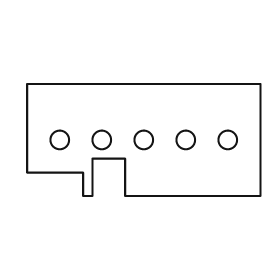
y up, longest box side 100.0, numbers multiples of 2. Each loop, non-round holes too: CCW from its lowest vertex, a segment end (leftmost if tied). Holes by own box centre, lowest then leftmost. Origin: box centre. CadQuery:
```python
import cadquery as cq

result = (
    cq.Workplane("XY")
    .moveTo(-26.0, -24.0)
    .lineTo(-22.0, -24.0)
    .lineTo(-22.0, -8.0)
    .lineTo(-8.0, -8.0)
    .lineTo(-8.0, -24.0)
    .lineTo(50.0, -24.0)
    .lineTo(50.0, 24.0)
    .lineTo(-50.0, 24.0)
    .lineTo(-50.0, -14.0)
    .lineTo(-26.0, -14.0)
    .close()
    .moveTo(-36.0, 0.0)
    .circle(4.0)
    .moveTo(-18.0, 0.0)
    .circle(4.0)
    .moveTo(0.0, 0.0)
    .circle(4.0)
    .moveTo(18.0, 0.0)
    .circle(4.0)
    .moveTo(36.0, 0.0)
    .circle(4.0)
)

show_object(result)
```